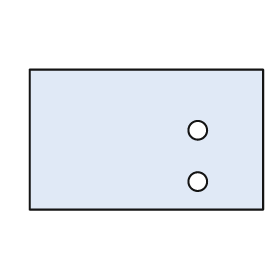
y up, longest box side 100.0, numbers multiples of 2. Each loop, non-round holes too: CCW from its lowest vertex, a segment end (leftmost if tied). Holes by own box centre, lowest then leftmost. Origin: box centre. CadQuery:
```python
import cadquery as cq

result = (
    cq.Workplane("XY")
    .moveTo(-50.0, -30.0)
    .lineTo(50.0, -30.0)
    .lineTo(50.0, 30.0)
    .lineTo(-50.0, 30.0)
    .close()
    .moveTo(22.0, -18.0)
    .circle(4.0)
    .moveTo(22.0, 4.0)
    .circle(4.0)
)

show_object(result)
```